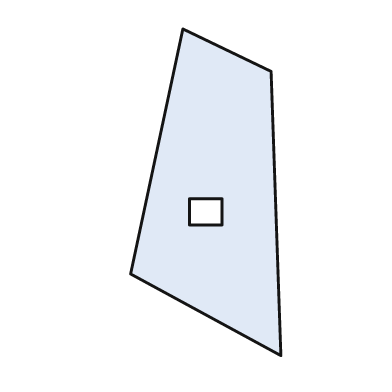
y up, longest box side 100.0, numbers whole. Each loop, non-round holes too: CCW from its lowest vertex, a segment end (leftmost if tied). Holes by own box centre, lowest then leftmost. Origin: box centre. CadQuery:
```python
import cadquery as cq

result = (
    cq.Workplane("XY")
    .moveTo(23.0, -50.0)
    .lineTo(20.0, 37.0)
    .lineTo(-7.0, 50.0)
    .lineTo(-23.0, -25.0)
    .close()
    .moveTo(-5.0, -10.0)
    .lineTo(5.0, -10.0)
    .lineTo(5.0, -2.0)
    .lineTo(-5.0, -2.0)
    .close()
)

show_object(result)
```